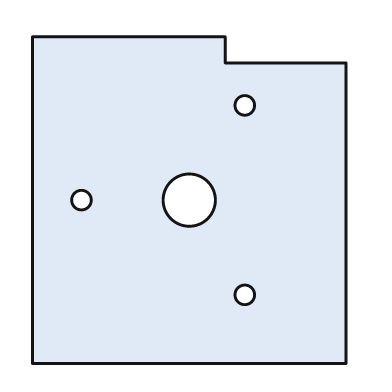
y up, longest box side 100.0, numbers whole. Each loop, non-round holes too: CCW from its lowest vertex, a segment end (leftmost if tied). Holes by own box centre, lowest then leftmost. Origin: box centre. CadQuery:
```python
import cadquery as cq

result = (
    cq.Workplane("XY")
    .moveTo(-48.0, -50.0)
    .lineTo(48.0, -50.0)
    .lineTo(48.0, 42.0)
    .lineTo(11.0, 42.0)
    .lineTo(11.0, 50.0)
    .lineTo(-48.0, 50.0)
    .close()
    .moveTo(17.0, -29.0)
    .circle(3.0)
    .moveTo(-33.0, 0.0)
    .circle(3.0)
    .moveTo(0.0, 0.0)
    .circle(8.0)
    .moveTo(17.0, 29.0)
    .circle(3.0)
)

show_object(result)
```